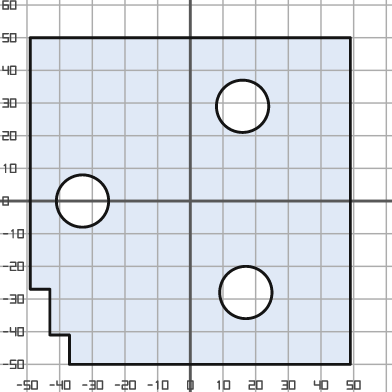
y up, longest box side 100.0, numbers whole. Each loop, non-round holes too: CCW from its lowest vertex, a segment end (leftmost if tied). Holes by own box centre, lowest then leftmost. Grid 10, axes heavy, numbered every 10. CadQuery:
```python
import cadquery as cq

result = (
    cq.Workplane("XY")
    .moveTo(-37.0, -50.0)
    .lineTo(49.0, -50.0)
    .lineTo(49.0, 50.0)
    .lineTo(-49.0, 50.0)
    .lineTo(-49.0, -27.0)
    .lineTo(-43.0, -27.0)
    .lineTo(-43.0, -41.0)
    .lineTo(-37.0, -41.0)
    .close()
    .moveTo(17.0, -28.0)
    .circle(8.0)
    .moveTo(-33.0, 0.0)
    .circle(8.0)
    .moveTo(16.0, 29.0)
    .circle(8.0)
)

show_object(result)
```